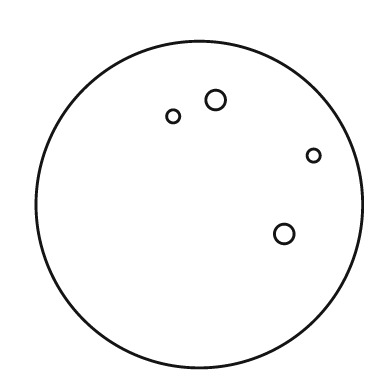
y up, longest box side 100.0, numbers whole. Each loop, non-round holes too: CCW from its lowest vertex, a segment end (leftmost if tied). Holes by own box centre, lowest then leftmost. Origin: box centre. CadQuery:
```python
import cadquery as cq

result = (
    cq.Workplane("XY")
    .moveTo(0.0, 0.0)
    .circle(50.0)
    .moveTo(26.0, -9.0)
    .circle(3.0)
    .moveTo(35.0, 15.0)
    .circle(2.0)
    .moveTo(-8.0, 27.0)
    .circle(2.0)
    .moveTo(5.0, 32.0)
    .circle(3.0)
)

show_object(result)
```